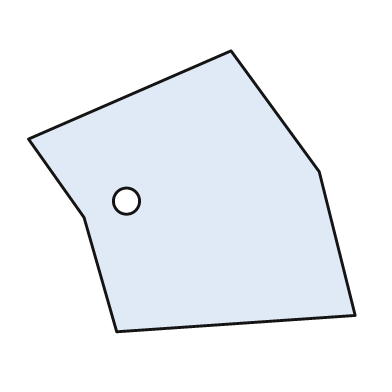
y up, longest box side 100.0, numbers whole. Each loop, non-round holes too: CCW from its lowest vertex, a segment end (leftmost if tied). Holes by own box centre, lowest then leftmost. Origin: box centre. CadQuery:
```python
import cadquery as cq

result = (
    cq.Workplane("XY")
    .moveTo(-23.0, -43.0)
    .lineTo(50.0, -38.0)
    .lineTo(39.0, 6.0)
    .lineTo(12.0, 43.0)
    .lineTo(-50.0, 16.0)
    .lineTo(-33.0, -8.0)
    .close()
    .moveTo(-20.0, -3.0)
    .circle(4.0)
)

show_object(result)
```